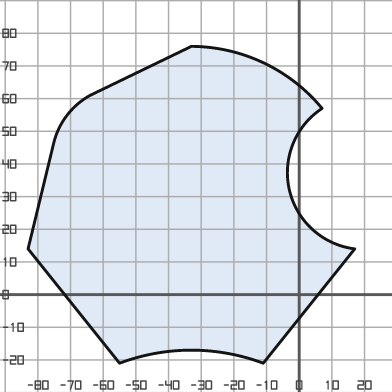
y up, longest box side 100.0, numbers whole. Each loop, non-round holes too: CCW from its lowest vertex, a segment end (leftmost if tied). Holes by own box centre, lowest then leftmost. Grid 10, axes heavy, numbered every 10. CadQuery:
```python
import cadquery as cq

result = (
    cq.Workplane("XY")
    .moveTo(-55.0, -21.0)
    .threePointArc((-33.0, -17.0), (-11.0, -21.0))
    .lineTo(17.0, 14.0)
    .threePointArc((-3.0, 32.0), (7.0, 57.0))
    .threePointArc((-11.0, 71.0), (-33.0, 76.0))
    .lineTo(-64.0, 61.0)
    .threePointArc((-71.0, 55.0), (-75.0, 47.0))
    .lineTo(-83.0, 14.0)
    .close()
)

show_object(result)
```